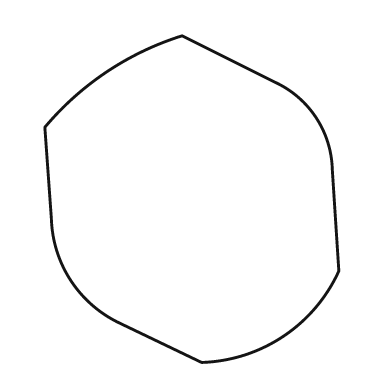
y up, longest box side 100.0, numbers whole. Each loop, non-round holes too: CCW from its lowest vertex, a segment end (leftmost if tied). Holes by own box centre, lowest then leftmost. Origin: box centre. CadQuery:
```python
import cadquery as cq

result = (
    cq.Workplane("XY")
    .moveTo(3.0, -50.0)
    .threePointArc((28.0, -42.0), (45.0, -22.0))
    .lineTo(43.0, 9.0)
    .threePointArc((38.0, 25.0), (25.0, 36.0))
    .lineTo(-3.0, 50.0)
    .threePointArc((-26.0, 39.0), (-45.0, 22.0))
    .lineTo(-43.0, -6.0)
    .threePointArc((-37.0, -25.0), (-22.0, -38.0))
    .close()
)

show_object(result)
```